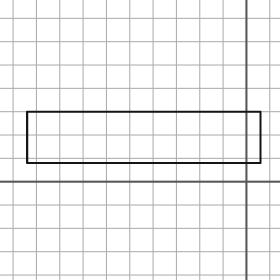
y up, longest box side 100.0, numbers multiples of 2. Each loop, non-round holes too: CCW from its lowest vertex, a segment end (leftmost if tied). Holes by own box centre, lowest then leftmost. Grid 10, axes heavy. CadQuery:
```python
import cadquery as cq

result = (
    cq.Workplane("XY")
    .moveTo(-94.0, 8.0)
    .lineTo(6.0, 8.0)
    .lineTo(6.0, 30.0)
    .lineTo(-94.0, 30.0)
    .close()
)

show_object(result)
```